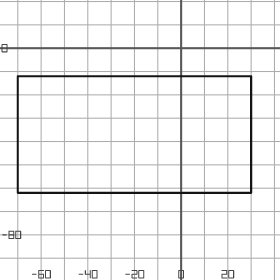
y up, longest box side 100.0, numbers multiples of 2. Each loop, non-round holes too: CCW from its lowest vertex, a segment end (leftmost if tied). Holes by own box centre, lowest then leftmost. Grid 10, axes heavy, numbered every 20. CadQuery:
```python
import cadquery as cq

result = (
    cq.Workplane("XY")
    .moveTo(-70.0, -62.0)
    .lineTo(30.0, -62.0)
    .lineTo(30.0, -12.0)
    .lineTo(-70.0, -12.0)
    .close()
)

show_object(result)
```